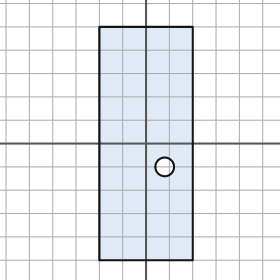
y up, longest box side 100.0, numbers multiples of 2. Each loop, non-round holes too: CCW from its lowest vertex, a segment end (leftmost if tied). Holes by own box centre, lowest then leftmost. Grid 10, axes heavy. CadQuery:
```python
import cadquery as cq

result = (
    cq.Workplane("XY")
    .moveTo(-20.0, -50.0)
    .lineTo(20.0, -50.0)
    .lineTo(20.0, 50.0)
    .lineTo(-20.0, 50.0)
    .close()
    .moveTo(8.0, -10.0)
    .circle(4.0)
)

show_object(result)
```